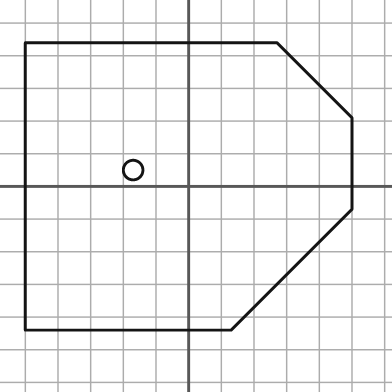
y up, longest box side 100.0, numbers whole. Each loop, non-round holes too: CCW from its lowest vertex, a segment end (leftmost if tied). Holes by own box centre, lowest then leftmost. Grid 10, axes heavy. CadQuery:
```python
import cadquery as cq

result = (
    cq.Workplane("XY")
    .moveTo(-50.0, -44.0)
    .lineTo(13.0, -44.0)
    .lineTo(50.0, -7.0)
    .lineTo(50.0, 21.0)
    .lineTo(27.0, 44.0)
    .lineTo(-50.0, 44.0)
    .close()
    .moveTo(-17.0, 5.0)
    .circle(3.0)
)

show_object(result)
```